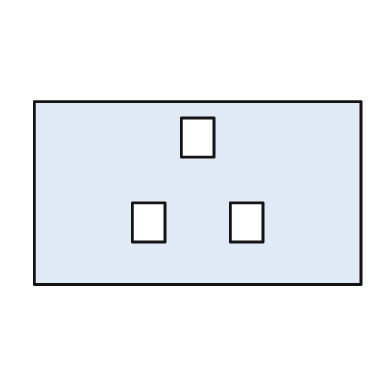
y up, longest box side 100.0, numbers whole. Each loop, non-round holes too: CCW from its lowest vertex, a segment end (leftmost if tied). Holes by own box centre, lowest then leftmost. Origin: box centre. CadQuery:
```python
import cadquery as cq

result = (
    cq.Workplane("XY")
    .moveTo(-50.0, -28.0)
    .lineTo(50.0, -28.0)
    .lineTo(50.0, 28.0)
    .lineTo(-50.0, 28.0)
    .close()
    .moveTo(-20.0, -15.0)
    .lineTo(-10.0, -15.0)
    .lineTo(-10.0, -3.0)
    .lineTo(-20.0, -3.0)
    .close()
    .moveTo(10.0, -15.0)
    .lineTo(20.0, -15.0)
    .lineTo(20.0, -3.0)
    .lineTo(10.0, -3.0)
    .close()
    .moveTo(-5.0, 11.0)
    .lineTo(5.0, 11.0)
    .lineTo(5.0, 23.0)
    .lineTo(-5.0, 23.0)
    .close()
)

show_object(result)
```